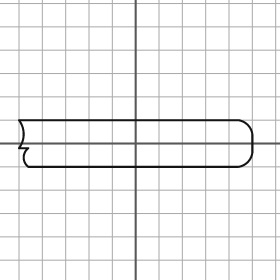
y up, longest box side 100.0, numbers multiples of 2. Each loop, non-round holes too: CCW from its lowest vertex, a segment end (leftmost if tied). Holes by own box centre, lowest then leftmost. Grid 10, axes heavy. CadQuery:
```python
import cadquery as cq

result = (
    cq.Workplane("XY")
    .moveTo(-46.0, -10.0)
    .lineTo(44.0, -10.0)
    .threePointArc((48.0, -8.0), (50.0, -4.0))
    .lineTo(50.0, 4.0)
    .threePointArc((48.0, 8.0), (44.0, 10.0))
    .lineTo(-50.0, 10.0)
    .threePointArc((-48.0, 4.0), (-50.0, -2.0))
    .lineTo(-46.0, -2.0)
    .threePointArc((-48.0, -6.0), (-46.0, -10.0))
    .close()
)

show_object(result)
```